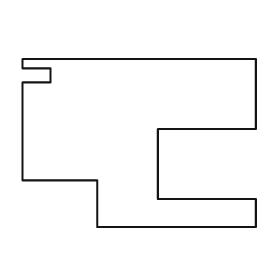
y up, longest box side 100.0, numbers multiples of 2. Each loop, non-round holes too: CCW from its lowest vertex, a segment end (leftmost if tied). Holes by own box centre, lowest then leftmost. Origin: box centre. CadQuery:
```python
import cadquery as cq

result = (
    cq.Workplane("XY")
    .moveTo(-18.0, -36.0)
    .lineTo(50.0, -36.0)
    .lineTo(50.0, -24.0)
    .lineTo(8.0, -24.0)
    .lineTo(8.0, 6.0)
    .lineTo(50.0, 6.0)
    .lineTo(50.0, 36.0)
    .lineTo(-50.0, 36.0)
    .lineTo(-50.0, 32.0)
    .lineTo(-38.0, 32.0)
    .lineTo(-38.0, 26.0)
    .lineTo(-50.0, 26.0)
    .lineTo(-50.0, -16.0)
    .lineTo(-18.0, -16.0)
    .close()
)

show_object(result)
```